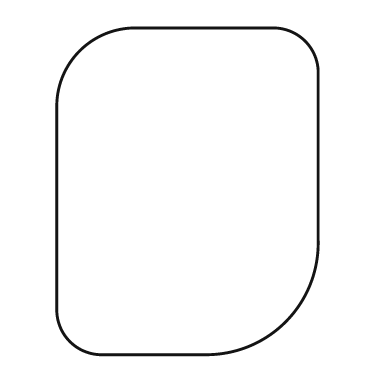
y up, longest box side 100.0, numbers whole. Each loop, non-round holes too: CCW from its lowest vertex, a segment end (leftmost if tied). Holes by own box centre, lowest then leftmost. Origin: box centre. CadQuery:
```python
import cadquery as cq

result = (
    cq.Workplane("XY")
    .moveTo(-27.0, -50.0)
    .lineTo(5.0, -50.0)
    .threePointArc((30.0, -40.0), (40.0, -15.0))
    .lineTo(40.0, 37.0)
    .threePointArc((36.0, 46.0), (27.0, 50.0))
    .lineTo(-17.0, 50.0)
    .threePointArc((-33.0, 43.0), (-40.0, 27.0))
    .lineTo(-40.0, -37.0)
    .threePointArc((-36.0, -46.0), (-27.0, -50.0))
    .close()
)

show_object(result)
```